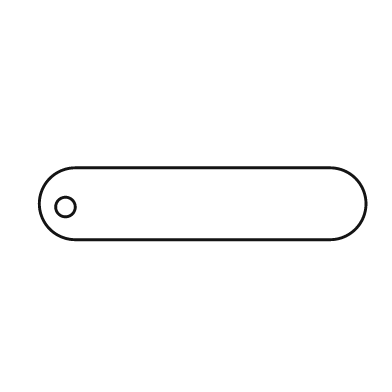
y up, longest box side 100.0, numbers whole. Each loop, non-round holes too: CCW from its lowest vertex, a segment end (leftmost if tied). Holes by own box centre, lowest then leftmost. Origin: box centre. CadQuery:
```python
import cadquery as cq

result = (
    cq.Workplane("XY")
    .moveTo(-39.0, -11.0)
    .lineTo(39.0, -11.0)
    .threePointArc((50.0, 0.0), (39.0, 11.0))
    .lineTo(-39.0, 11.0)
    .threePointArc((-50.0, 0.0), (-39.0, -11.0))
    .close()
    .moveTo(-42.0, -1.0)
    .circle(3.0)
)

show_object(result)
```